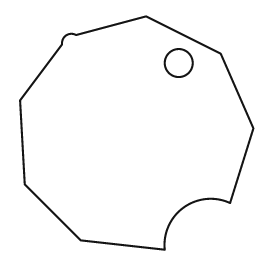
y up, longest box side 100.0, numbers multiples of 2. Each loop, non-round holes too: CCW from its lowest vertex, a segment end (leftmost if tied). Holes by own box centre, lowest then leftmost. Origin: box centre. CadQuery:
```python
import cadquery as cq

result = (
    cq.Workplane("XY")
    .moveTo(12.0, -50.0)
    .threePointArc((20.0, -32.0), (40.0, -30.0))
    .lineTo(50.0, 2.0)
    .lineTo(36.0, 34.0)
    .lineTo(4.0, 50.0)
    .lineTo(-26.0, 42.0)
    .threePointArc((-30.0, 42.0), (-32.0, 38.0))
    .lineTo(-50.0, 14.0)
    .lineTo(-48.0, -22.0)
    .lineTo(-24.0, -46.0)
    .close()
    .moveTo(18.0, 30.0)
    .circle(6.0)
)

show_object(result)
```